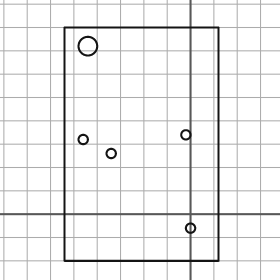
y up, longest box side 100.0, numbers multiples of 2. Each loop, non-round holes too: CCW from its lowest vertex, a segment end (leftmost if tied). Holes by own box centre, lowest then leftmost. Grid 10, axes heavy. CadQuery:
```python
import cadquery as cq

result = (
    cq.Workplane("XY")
    .moveTo(-54.0, -20.0)
    .lineTo(12.0, -20.0)
    .lineTo(12.0, 80.0)
    .lineTo(-54.0, 80.0)
    .close()
    .moveTo(0.0, -6.0)
    .circle(2.0)
    .moveTo(-34.0, 26.0)
    .circle(2.0)
    .moveTo(-46.0, 32.0)
    .circle(2.0)
    .moveTo(-2.0, 34.0)
    .circle(2.0)
    .moveTo(-44.0, 72.0)
    .circle(4.0)
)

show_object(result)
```